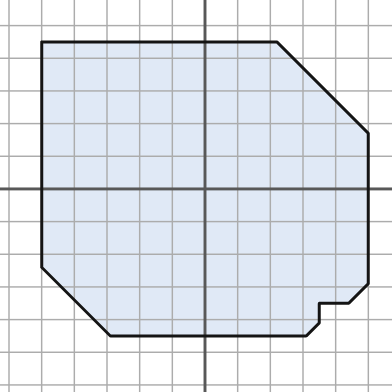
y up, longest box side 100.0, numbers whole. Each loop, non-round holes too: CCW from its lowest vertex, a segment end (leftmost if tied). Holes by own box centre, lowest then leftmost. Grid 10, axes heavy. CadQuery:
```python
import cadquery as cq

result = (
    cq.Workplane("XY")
    .moveTo(-29.0, -45.0)
    .lineTo(31.0, -45.0)
    .lineTo(35.0, -41.0)
    .lineTo(35.0, -35.0)
    .lineTo(44.0, -35.0)
    .lineTo(50.0, -29.0)
    .lineTo(50.0, 17.0)
    .lineTo(22.0, 45.0)
    .lineTo(-50.0, 45.0)
    .lineTo(-50.0, -24.0)
    .close()
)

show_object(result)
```